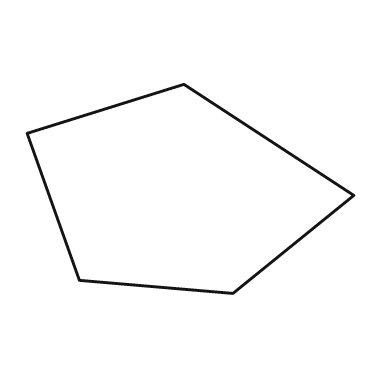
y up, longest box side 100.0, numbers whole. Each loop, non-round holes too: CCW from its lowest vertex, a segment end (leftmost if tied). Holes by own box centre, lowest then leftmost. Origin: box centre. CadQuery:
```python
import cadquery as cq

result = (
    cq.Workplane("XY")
    .moveTo(13.0, -32.0)
    .lineTo(50.0, -2.0)
    .lineTo(-2.0, 32.0)
    .lineTo(-50.0, 17.0)
    .lineTo(-34.0, -28.0)
    .close()
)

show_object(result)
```